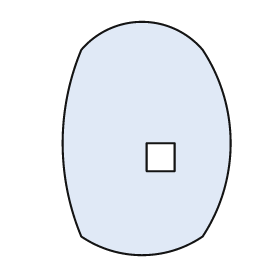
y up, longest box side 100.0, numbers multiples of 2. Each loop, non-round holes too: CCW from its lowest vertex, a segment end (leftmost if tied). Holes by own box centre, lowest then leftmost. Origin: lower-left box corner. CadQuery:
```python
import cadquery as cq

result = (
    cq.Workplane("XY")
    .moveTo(8.0, 8.0)
    .threePointArc((34.0, 0.0), (60.0, 8.0))
    .threePointArc((72.0, 48.0), (60.0, 88.0))
    .threePointArc((34.0, 100.0), (8.0, 88.0))
    .threePointArc((0.0, 48.0), (8.0, 8.0))
    .close()
    .moveTo(36.0, 36.0)
    .lineTo(48.0, 36.0)
    .lineTo(48.0, 48.0)
    .lineTo(36.0, 48.0)
    .close()
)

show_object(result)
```